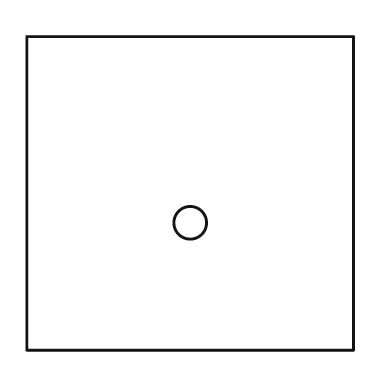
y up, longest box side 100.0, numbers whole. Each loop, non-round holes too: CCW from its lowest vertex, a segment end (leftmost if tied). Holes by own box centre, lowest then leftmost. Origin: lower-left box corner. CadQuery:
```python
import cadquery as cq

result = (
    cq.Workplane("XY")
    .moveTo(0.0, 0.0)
    .lineTo(100.0, 0.0)
    .lineTo(100.0, 96.0)
    .lineTo(0.0, 96.0)
    .close()
    .moveTo(50.0, 39.0)
    .circle(5.0)
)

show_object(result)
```